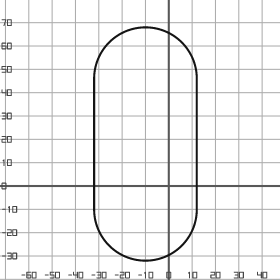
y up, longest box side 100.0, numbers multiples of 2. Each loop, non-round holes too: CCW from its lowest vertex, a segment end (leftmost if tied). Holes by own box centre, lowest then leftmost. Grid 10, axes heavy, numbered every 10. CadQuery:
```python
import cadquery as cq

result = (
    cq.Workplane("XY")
    .moveTo(-32.0, -10.0)
    .threePointArc((-10.0, -32.0), (12.0, -10.0))
    .lineTo(12.0, 46.0)
    .threePointArc((-10.0, 68.0), (-32.0, 46.0))
    .close()
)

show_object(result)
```